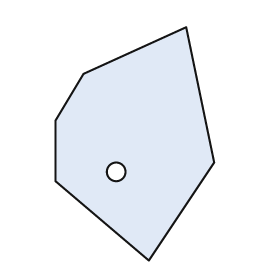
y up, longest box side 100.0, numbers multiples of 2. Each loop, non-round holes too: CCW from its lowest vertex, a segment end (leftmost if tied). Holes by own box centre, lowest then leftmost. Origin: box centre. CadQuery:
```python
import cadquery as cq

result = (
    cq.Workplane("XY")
    .moveTo(6.0, -50.0)
    .lineTo(34.0, -8.0)
    .lineTo(22.0, 50.0)
    .lineTo(-22.0, 30.0)
    .lineTo(-34.0, 10.0)
    .lineTo(-34.0, -16.0)
    .close()
    .moveTo(-8.0, -12.0)
    .circle(4.0)
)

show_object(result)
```